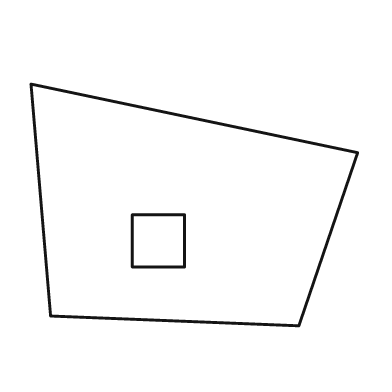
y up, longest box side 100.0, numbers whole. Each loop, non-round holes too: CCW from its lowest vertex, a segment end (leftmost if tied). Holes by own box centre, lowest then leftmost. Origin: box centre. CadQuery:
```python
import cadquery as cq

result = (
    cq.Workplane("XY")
    .moveTo(32.0, -37.0)
    .lineTo(50.0, 16.0)
    .lineTo(-50.0, 37.0)
    .lineTo(-44.0, -34.0)
    .close()
    .moveTo(-19.0, -19.0)
    .lineTo(-3.0, -19.0)
    .lineTo(-3.0, -3.0)
    .lineTo(-19.0, -3.0)
    .close()
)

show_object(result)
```